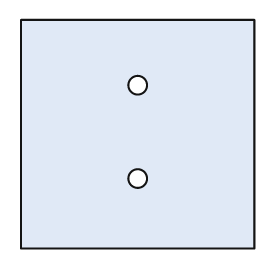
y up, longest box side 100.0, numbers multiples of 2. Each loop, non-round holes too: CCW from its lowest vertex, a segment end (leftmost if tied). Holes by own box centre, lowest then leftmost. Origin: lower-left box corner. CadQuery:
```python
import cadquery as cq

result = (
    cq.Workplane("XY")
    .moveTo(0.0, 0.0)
    .lineTo(100.0, 0.0)
    .lineTo(100.0, 98.0)
    .lineTo(0.0, 98.0)
    .close()
    .moveTo(50.0, 30.0)
    .circle(4.0)
    .moveTo(50.0, 70.0)
    .circle(4.0)
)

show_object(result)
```